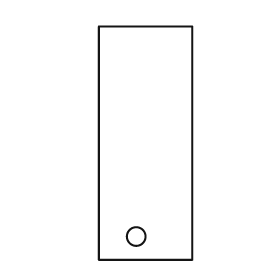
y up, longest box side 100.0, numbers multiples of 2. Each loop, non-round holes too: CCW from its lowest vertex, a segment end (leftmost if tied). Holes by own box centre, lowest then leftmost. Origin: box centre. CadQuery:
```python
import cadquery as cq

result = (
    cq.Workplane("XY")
    .moveTo(-20.0, -50.0)
    .lineTo(20.0, -50.0)
    .lineTo(20.0, 50.0)
    .lineTo(-20.0, 50.0)
    .close()
    .moveTo(-4.0, -40.0)
    .circle(4.0)
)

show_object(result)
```